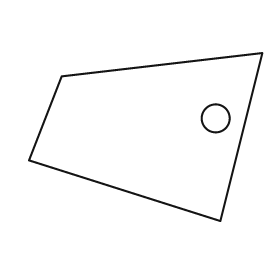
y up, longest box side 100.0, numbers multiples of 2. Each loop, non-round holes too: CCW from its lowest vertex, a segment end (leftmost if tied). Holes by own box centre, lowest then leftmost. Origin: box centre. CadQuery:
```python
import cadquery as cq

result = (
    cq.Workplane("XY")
    .moveTo(32.0, -36.0)
    .lineTo(50.0, 36.0)
    .lineTo(-36.0, 26.0)
    .lineTo(-50.0, -10.0)
    .close()
    .moveTo(30.0, 8.0)
    .circle(6.0)
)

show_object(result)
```